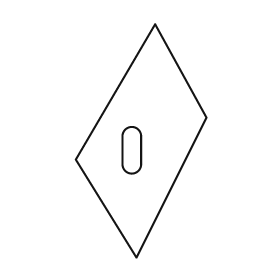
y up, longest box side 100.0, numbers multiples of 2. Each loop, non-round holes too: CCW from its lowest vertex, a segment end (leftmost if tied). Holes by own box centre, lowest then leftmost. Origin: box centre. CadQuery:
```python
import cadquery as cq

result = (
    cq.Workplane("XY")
    .moveTo(-2.0, -50.0)
    .lineTo(28.0, 10.0)
    .lineTo(6.0, 50.0)
    .lineTo(-28.0, -8.0)
    .close()
    .moveTo(-8.0, -10.0)
    .threePointArc((-4.0, -14.0), (0.0, -10.0))
    .lineTo(0.0, 2.0)
    .threePointArc((-4.0, 6.0), (-8.0, 2.0))
    .close()
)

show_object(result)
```